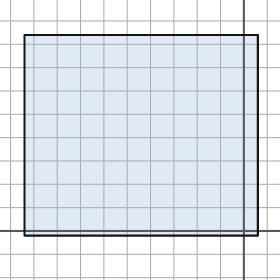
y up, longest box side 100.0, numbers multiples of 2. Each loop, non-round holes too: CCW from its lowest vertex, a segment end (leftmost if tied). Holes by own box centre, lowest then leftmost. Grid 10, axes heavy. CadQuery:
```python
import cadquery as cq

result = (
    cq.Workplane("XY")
    .moveTo(-94.0, -2.0)
    .lineTo(6.0, -2.0)
    .lineTo(6.0, 84.0)
    .lineTo(-94.0, 84.0)
    .close()
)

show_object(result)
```